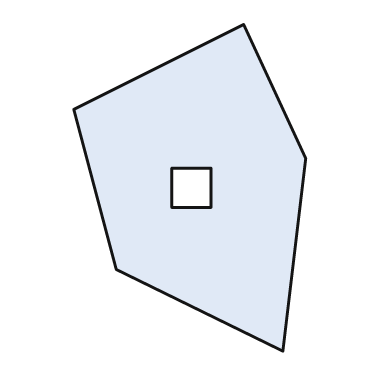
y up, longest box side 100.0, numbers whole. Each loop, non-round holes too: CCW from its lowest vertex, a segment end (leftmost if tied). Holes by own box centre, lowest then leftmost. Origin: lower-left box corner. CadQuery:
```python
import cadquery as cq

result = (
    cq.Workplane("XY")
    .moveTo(64.0, 0.0)
    .lineTo(71.0, 59.0)
    .lineTo(52.0, 100.0)
    .lineTo(0.0, 74.0)
    .lineTo(13.0, 25.0)
    .close()
    .moveTo(30.0, 44.0)
    .lineTo(42.0, 44.0)
    .lineTo(42.0, 56.0)
    .lineTo(30.0, 56.0)
    .close()
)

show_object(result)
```